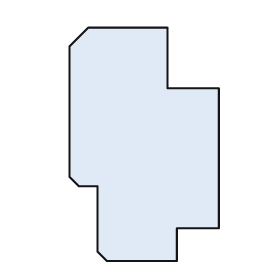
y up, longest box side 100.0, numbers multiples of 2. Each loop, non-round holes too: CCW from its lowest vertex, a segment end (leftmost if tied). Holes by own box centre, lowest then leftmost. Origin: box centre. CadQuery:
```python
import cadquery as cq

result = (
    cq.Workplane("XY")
    .moveTo(-16.0, -50.0)
    .lineTo(14.0, -50.0)
    .lineTo(14.0, -36.0)
    .lineTo(32.0, -36.0)
    .lineTo(32.0, 24.0)
    .lineTo(10.0, 24.0)
    .lineTo(10.0, 50.0)
    .lineTo(-24.0, 50.0)
    .lineTo(-32.0, 42.0)
    .lineTo(-32.0, -14.0)
    .lineTo(-28.0, -18.0)
    .lineTo(-20.0, -18.0)
    .lineTo(-20.0, -46.0)
    .close()
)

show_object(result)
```